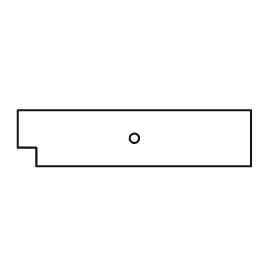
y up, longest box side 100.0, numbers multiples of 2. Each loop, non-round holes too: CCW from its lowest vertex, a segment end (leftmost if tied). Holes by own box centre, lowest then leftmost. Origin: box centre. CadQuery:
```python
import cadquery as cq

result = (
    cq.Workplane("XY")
    .moveTo(-42.0, -12.0)
    .lineTo(50.0, -12.0)
    .lineTo(50.0, 12.0)
    .lineTo(-50.0, 12.0)
    .lineTo(-50.0, -4.0)
    .lineTo(-42.0, -4.0)
    .close()
    .moveTo(0.0, 0.0)
    .circle(2.0)
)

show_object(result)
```